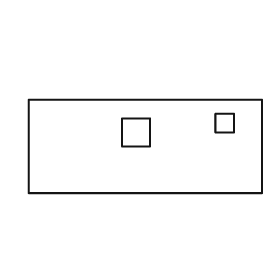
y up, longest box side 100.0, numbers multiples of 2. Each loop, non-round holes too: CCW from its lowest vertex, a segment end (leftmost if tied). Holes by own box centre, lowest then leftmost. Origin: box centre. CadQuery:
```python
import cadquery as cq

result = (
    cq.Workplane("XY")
    .moveTo(-50.0, -20.0)
    .lineTo(50.0, -20.0)
    .lineTo(50.0, 20.0)
    .lineTo(-50.0, 20.0)
    .close()
    .moveTo(-10.0, 0.0)
    .lineTo(2.0, 0.0)
    .lineTo(2.0, 12.0)
    .lineTo(-10.0, 12.0)
    .close()
    .moveTo(30.0, 6.0)
    .lineTo(38.0, 6.0)
    .lineTo(38.0, 14.0)
    .lineTo(30.0, 14.0)
    .close()
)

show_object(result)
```